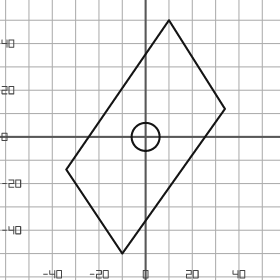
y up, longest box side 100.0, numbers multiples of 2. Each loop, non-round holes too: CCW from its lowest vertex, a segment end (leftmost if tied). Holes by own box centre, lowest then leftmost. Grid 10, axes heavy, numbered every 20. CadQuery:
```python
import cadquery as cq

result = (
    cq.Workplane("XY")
    .moveTo(-10.0, -50.0)
    .lineTo(34.0, 12.0)
    .lineTo(10.0, 50.0)
    .lineTo(-34.0, -14.0)
    .close()
    .moveTo(0.0, 0.0)
    .circle(6.0)
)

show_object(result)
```